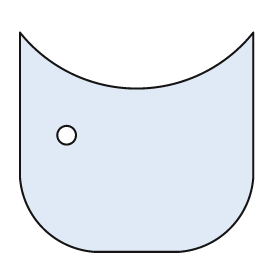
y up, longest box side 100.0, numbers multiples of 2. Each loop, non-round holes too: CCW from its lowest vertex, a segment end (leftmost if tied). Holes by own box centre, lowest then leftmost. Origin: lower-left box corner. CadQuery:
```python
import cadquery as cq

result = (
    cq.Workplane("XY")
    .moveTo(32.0, 0.0)
    .lineTo(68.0, 0.0)
    .threePointArc((90.0, 10.0), (100.0, 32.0))
    .lineTo(100.0, 94.0)
    .threePointArc((50.0, 70.0), (0.0, 94.0))
    .lineTo(0.0, 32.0)
    .threePointArc((10.0, 10.0), (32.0, 0.0))
    .close()
    .moveTo(20.0, 50.0)
    .circle(4.0)
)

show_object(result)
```